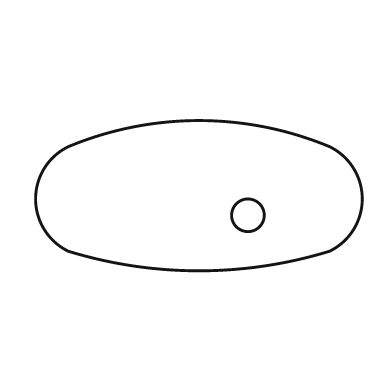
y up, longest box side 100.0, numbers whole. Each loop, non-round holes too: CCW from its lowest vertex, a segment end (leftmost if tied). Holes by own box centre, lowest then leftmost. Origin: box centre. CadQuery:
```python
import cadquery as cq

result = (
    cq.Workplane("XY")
    .moveTo(-40.0, -17.0)
    .threePointArc((0.0, -23.0), (40.0, -17.0))
    .threePointArc((50.0, -1.0), (40.0, 15.0))
    .threePointArc((0.0, 23.0), (-40.0, 15.0))
    .threePointArc((-50.0, -1.0), (-40.0, -17.0))
    .close()
    .moveTo(15.0, -6.0)
    .circle(5.0)
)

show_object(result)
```